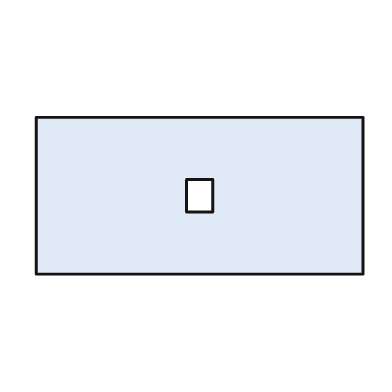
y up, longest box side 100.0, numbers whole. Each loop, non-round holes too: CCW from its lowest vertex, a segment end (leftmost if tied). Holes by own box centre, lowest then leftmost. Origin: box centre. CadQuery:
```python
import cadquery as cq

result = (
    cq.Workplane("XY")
    .moveTo(-50.0, -24.0)
    .lineTo(50.0, -24.0)
    .lineTo(50.0, 24.0)
    .lineTo(-50.0, 24.0)
    .close()
    .moveTo(-4.0, -5.0)
    .lineTo(4.0, -5.0)
    .lineTo(4.0, 5.0)
    .lineTo(-4.0, 5.0)
    .close()
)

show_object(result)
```